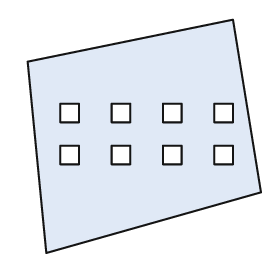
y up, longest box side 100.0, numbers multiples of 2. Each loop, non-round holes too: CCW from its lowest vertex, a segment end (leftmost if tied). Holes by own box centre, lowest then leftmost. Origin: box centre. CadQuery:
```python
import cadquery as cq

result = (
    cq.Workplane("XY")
    .moveTo(-42.0, -50.0)
    .lineTo(50.0, -24.0)
    .lineTo(38.0, 50.0)
    .lineTo(-50.0, 32.0)
    .close()
    .moveTo(-36.0, -12.0)
    .lineTo(-28.0, -12.0)
    .lineTo(-28.0, -4.0)
    .lineTo(-36.0, -4.0)
    .close()
    .moveTo(-14.0, -12.0)
    .lineTo(-6.0, -12.0)
    .lineTo(-6.0, -4.0)
    .lineTo(-14.0, -4.0)
    .close()
    .moveTo(8.0, -12.0)
    .lineTo(16.0, -12.0)
    .lineTo(16.0, -4.0)
    .lineTo(8.0, -4.0)
    .close()
    .moveTo(30.0, -12.0)
    .lineTo(38.0, -12.0)
    .lineTo(38.0, -4.0)
    .lineTo(30.0, -4.0)
    .close()
    .moveTo(-36.0, 6.0)
    .lineTo(-28.0, 6.0)
    .lineTo(-28.0, 14.0)
    .lineTo(-36.0, 14.0)
    .close()
    .moveTo(-14.0, 6.0)
    .lineTo(-6.0, 6.0)
    .lineTo(-6.0, 14.0)
    .lineTo(-14.0, 14.0)
    .close()
    .moveTo(8.0, 6.0)
    .lineTo(16.0, 6.0)
    .lineTo(16.0, 14.0)
    .lineTo(8.0, 14.0)
    .close()
    .moveTo(30.0, 6.0)
    .lineTo(38.0, 6.0)
    .lineTo(38.0, 14.0)
    .lineTo(30.0, 14.0)
    .close()
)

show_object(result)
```